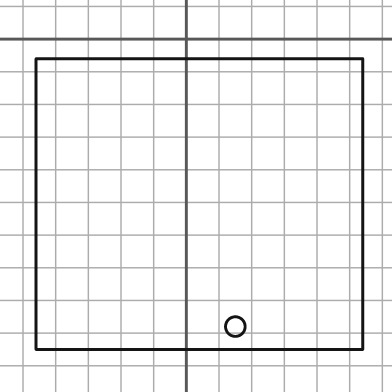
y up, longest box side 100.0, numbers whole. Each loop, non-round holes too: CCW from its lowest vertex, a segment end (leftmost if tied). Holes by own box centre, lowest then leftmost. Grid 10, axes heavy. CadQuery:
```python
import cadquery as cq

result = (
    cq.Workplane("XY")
    .moveTo(-46.0, -95.0)
    .lineTo(54.0, -95.0)
    .lineTo(54.0, -6.0)
    .lineTo(-46.0, -6.0)
    .close()
    .moveTo(15.0, -88.0)
    .circle(3.0)
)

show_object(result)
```